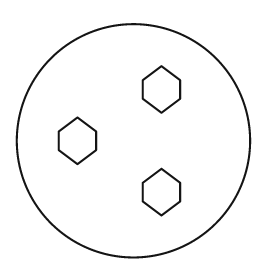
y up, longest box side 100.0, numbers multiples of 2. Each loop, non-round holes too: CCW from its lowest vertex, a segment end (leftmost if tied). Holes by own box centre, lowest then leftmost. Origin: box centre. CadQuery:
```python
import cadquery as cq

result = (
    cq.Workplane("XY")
    .moveTo(0.0, 0.0)
    .circle(50.0)
    .moveTo(12.0, -32.0)
    .lineTo(20.0, -26.0)
    .lineTo(20.0, -18.0)
    .lineTo(12.0, -12.0)
    .lineTo(4.0, -18.0)
    .lineTo(4.0, -26.0)
    .close()
    .moveTo(-24.0, -10.0)
    .lineTo(-16.0, -4.0)
    .lineTo(-16.0, 4.0)
    .lineTo(-24.0, 10.0)
    .lineTo(-32.0, 4.0)
    .lineTo(-32.0, -4.0)
    .close()
    .moveTo(12.0, 12.0)
    .lineTo(20.0, 18.0)
    .lineTo(20.0, 26.0)
    .lineTo(12.0, 32.0)
    .lineTo(4.0, 26.0)
    .lineTo(4.0, 18.0)
    .close()
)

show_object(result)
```